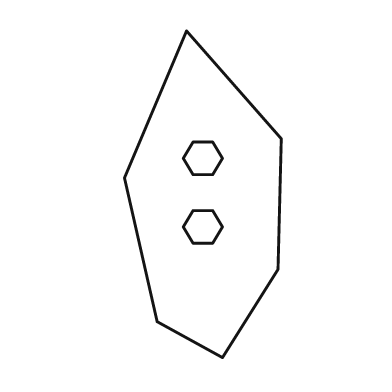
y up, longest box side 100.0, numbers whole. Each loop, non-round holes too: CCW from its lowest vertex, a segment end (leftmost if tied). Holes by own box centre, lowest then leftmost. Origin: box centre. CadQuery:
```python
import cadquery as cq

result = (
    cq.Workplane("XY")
    .moveTo(6.0, -50.0)
    .lineTo(23.0, -23.0)
    .lineTo(24.0, 17.0)
    .lineTo(-5.0, 50.0)
    .lineTo(-24.0, 5.0)
    .lineTo(-14.0, -39.0)
    .close()
    .moveTo(-3.0, -15.0)
    .lineTo(3.0, -15.0)
    .lineTo(6.0, -10.0)
    .lineTo(3.0, -5.0)
    .lineTo(-3.0, -5.0)
    .lineTo(-6.0, -10.0)
    .close()
    .moveTo(-3.0, 6.0)
    .lineTo(3.0, 6.0)
    .lineTo(6.0, 11.0)
    .lineTo(3.0, 16.0)
    .lineTo(-3.0, 16.0)
    .lineTo(-6.0, 11.0)
    .close()
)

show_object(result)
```